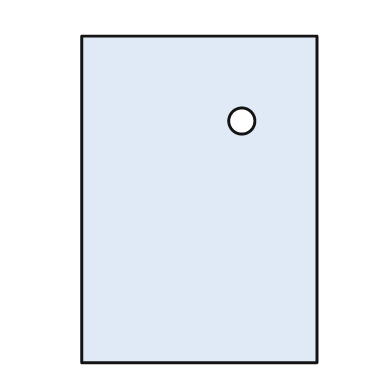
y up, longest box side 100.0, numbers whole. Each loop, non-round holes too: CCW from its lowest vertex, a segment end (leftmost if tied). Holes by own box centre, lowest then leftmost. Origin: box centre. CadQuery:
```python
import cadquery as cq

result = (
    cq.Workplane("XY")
    .moveTo(-36.0, -50.0)
    .lineTo(36.0, -50.0)
    .lineTo(36.0, 50.0)
    .lineTo(-36.0, 50.0)
    .close()
    .moveTo(13.0, 24.0)
    .circle(4.0)
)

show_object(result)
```